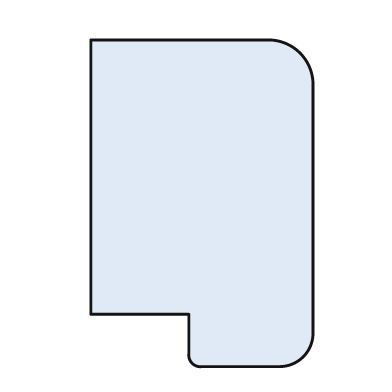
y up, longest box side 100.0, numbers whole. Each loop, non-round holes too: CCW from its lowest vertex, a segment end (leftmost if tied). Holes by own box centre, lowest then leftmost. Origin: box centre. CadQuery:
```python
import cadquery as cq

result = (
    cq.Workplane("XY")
    .moveTo(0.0, -50.0)
    .lineTo(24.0, -50.0)
    .threePointArc((31.0, -47.0), (34.0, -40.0))
    .lineTo(34.0, 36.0)
    .threePointArc((30.0, 46.0), (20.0, 50.0))
    .lineTo(-34.0, 50.0)
    .lineTo(-34.0, -34.0)
    .lineTo(-4.0, -34.0)
    .lineTo(-4.0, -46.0)
    .threePointArc((-3.0, -49.0), (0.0, -50.0))
    .close()
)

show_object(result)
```